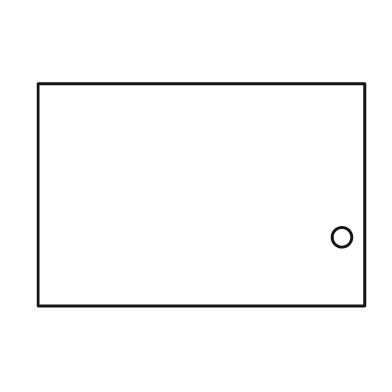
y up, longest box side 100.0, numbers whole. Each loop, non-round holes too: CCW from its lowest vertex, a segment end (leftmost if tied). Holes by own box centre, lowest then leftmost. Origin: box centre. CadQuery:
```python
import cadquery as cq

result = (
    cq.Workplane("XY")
    .moveTo(-50.0, -34.0)
    .lineTo(50.0, -34.0)
    .lineTo(50.0, 34.0)
    .lineTo(-50.0, 34.0)
    .close()
    .moveTo(43.0, -13.0)
    .circle(3.0)
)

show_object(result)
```